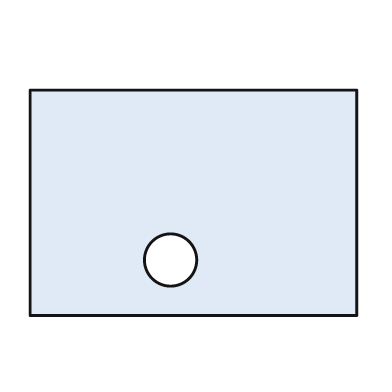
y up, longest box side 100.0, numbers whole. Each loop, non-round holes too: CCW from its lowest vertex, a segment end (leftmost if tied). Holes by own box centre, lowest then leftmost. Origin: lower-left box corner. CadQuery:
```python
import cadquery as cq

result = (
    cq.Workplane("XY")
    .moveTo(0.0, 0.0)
    .lineTo(100.0, 0.0)
    .lineTo(100.0, 69.0)
    .lineTo(0.0, 69.0)
    .close()
    .moveTo(43.0, 17.0)
    .circle(8.0)
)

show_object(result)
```